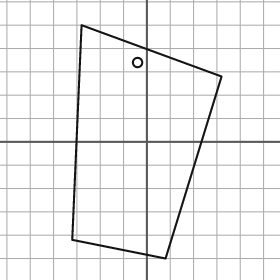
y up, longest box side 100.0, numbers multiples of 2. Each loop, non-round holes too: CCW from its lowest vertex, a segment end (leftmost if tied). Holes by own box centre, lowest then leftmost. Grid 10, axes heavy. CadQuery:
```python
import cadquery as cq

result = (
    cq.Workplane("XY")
    .moveTo(8.0, -50.0)
    .lineTo(32.0, 28.0)
    .lineTo(-28.0, 50.0)
    .lineTo(-32.0, -42.0)
    .close()
    .moveTo(-4.0, 34.0)
    .circle(2.0)
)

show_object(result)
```